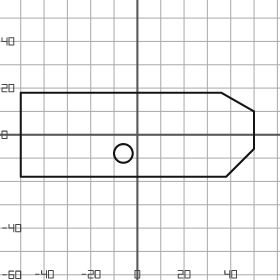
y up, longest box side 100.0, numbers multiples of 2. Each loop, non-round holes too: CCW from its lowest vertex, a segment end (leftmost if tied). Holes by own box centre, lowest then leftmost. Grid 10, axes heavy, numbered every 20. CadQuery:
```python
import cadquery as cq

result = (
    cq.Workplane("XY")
    .moveTo(-50.0, -18.0)
    .lineTo(38.0, -18.0)
    .lineTo(50.0, -6.0)
    .lineTo(50.0, 10.0)
    .lineTo(36.0, 18.0)
    .lineTo(-50.0, 18.0)
    .close()
    .moveTo(-6.0, -8.0)
    .circle(4.0)
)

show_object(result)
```